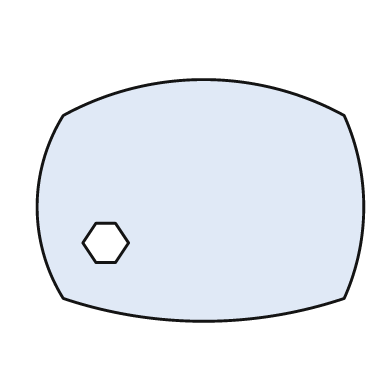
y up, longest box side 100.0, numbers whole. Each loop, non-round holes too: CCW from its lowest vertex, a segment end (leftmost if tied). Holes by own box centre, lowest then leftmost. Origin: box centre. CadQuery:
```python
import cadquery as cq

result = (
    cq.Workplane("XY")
    .moveTo(-42.0, -30.0)
    .threePointArc((1.0, -37.0), (44.0, -30.0))
    .threePointArc((50.0, -2.0), (44.0, 26.0))
    .threePointArc((1.0, 37.0), (-42.0, 26.0))
    .threePointArc((-50.0, -2.0), (-42.0, -30.0))
    .close()
    .moveTo(-32.0, -19.0)
    .lineTo(-26.0, -19.0)
    .lineTo(-22.0, -13.0)
    .lineTo(-26.0, -7.0)
    .lineTo(-32.0, -7.0)
    .lineTo(-36.0, -13.0)
    .close()
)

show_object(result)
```